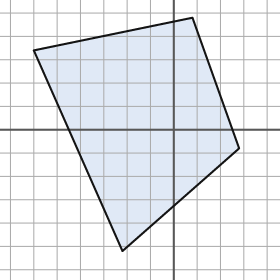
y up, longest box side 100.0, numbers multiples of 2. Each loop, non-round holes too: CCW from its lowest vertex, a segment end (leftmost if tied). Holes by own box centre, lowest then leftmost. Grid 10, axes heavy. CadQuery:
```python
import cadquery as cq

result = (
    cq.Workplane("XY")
    .moveTo(-22.0, -52.0)
    .lineTo(28.0, -8.0)
    .lineTo(8.0, 48.0)
    .lineTo(-60.0, 34.0)
    .close()
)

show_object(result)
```